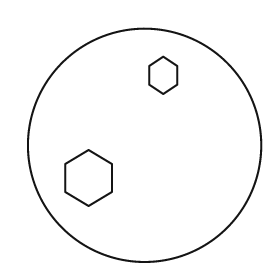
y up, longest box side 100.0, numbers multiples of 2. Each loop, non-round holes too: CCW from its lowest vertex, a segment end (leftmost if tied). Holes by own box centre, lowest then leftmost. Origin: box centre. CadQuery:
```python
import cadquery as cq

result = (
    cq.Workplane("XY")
    .moveTo(0.0, 0.0)
    .circle(50.0)
    .moveTo(-24.0, -26.0)
    .lineTo(-14.0, -20.0)
    .lineTo(-14.0, -8.0)
    .lineTo(-24.0, -2.0)
    .lineTo(-34.0, -8.0)
    .lineTo(-34.0, -20.0)
    .close()
    .moveTo(8.0, 22.0)
    .lineTo(14.0, 26.0)
    .lineTo(14.0, 34.0)
    .lineTo(8.0, 38.0)
    .lineTo(2.0, 34.0)
    .lineTo(2.0, 26.0)
    .close()
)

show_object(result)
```